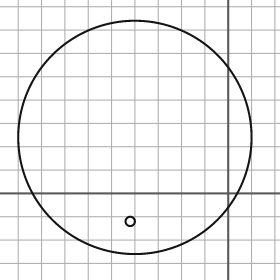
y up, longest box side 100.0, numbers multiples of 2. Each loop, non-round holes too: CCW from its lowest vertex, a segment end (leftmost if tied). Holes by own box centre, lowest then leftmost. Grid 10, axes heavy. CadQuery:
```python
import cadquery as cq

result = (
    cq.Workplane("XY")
    .moveTo(-40.0, 24.0)
    .circle(50.0)
    .moveTo(-42.0, -12.0)
    .circle(2.0)
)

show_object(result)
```